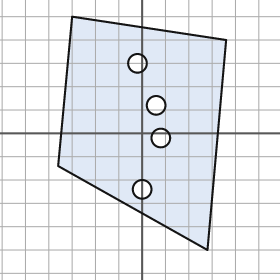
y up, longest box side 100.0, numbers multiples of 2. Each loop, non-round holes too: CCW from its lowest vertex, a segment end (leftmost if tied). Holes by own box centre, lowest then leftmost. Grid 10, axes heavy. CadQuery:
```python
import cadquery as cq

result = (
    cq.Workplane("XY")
    .moveTo(28.0, -50.0)
    .lineTo(36.0, 40.0)
    .lineTo(-30.0, 50.0)
    .lineTo(-36.0, -14.0)
    .close()
    .moveTo(0.0, -24.0)
    .circle(4.0)
    .moveTo(8.0, -2.0)
    .circle(4.0)
    .moveTo(6.0, 12.0)
    .circle(4.0)
    .moveTo(-2.0, 30.0)
    .circle(4.0)
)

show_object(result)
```